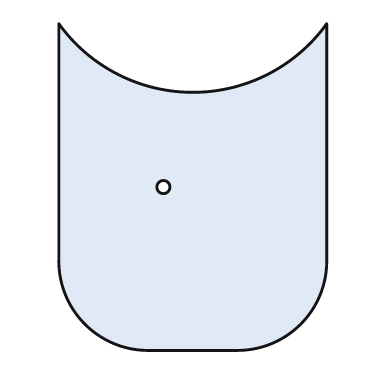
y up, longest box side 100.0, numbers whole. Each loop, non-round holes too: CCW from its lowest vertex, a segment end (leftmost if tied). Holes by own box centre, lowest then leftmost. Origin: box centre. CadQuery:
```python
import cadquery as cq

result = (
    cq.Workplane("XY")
    .moveTo(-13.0, -50.0)
    .lineTo(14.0, -50.0)
    .threePointArc((33.0, -42.0), (41.0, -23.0))
    .lineTo(41.0, 50.0)
    .threePointArc((0.0, 29.0), (-41.0, 50.0))
    .lineTo(-41.0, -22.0)
    .threePointArc((-33.0, -42.0), (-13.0, -50.0))
    .close()
    .moveTo(-9.0, 0.0)
    .circle(2.0)
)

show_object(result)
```